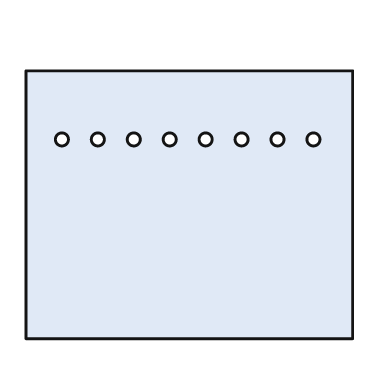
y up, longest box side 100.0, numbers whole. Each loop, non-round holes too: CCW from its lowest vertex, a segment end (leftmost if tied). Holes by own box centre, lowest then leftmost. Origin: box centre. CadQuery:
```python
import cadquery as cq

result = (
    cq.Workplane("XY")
    .moveTo(-50.0, -41.0)
    .lineTo(50.0, -41.0)
    .lineTo(50.0, 41.0)
    .lineTo(-50.0, 41.0)
    .close()
    .moveTo(-39.0, 20.0)
    .circle(2.0)
    .moveTo(-28.0, 20.0)
    .circle(2.0)
    .moveTo(-17.0, 20.0)
    .circle(2.0)
    .moveTo(-6.0, 20.0)
    .circle(2.0)
    .moveTo(5.0, 20.0)
    .circle(2.0)
    .moveTo(16.0, 20.0)
    .circle(2.0)
    .moveTo(27.0, 20.0)
    .circle(2.0)
    .moveTo(38.0, 20.0)
    .circle(2.0)
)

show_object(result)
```